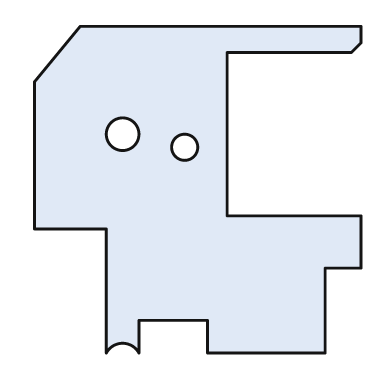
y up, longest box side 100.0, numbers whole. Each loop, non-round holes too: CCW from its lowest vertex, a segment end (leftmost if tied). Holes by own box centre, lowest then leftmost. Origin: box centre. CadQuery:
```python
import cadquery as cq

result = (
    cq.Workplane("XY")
    .moveTo(-28.0, -50.0)
    .threePointArc((-23.0, -47.0), (-18.0, -50.0))
    .lineTo(-18.0, -40.0)
    .lineTo(3.0, -40.0)
    .lineTo(3.0, -50.0)
    .lineTo(39.0, -50.0)
    .lineTo(39.0, -24.0)
    .lineTo(50.0, -24.0)
    .lineTo(50.0, -8.0)
    .lineTo(9.0, -8.0)
    .lineTo(9.0, 42.0)
    .lineTo(47.0, 42.0)
    .lineTo(50.0, 45.0)
    .lineTo(50.0, 50.0)
    .lineTo(-36.0, 50.0)
    .lineTo(-50.0, 33.0)
    .lineTo(-50.0, -12.0)
    .lineTo(-28.0, -12.0)
    .close()
    .moveTo(-4.0, 13.0)
    .circle(4.0)
    .moveTo(-23.0, 17.0)
    .circle(5.0)
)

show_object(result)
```